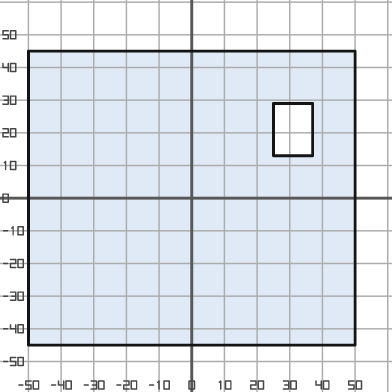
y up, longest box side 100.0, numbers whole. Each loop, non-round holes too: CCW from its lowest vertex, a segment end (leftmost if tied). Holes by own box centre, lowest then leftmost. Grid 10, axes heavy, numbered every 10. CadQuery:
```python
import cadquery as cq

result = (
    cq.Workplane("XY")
    .moveTo(-50.0, -45.0)
    .lineTo(50.0, -45.0)
    .lineTo(50.0, 45.0)
    .lineTo(-50.0, 45.0)
    .close()
    .moveTo(25.0, 13.0)
    .lineTo(37.0, 13.0)
    .lineTo(37.0, 29.0)
    .lineTo(25.0, 29.0)
    .close()
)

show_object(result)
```